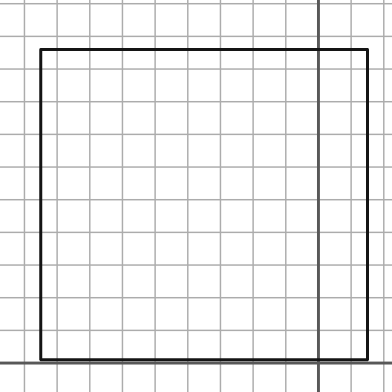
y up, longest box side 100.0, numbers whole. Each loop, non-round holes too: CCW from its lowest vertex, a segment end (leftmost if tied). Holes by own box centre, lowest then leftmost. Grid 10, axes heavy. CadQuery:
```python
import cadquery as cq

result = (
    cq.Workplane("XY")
    .moveTo(-85.0, 1.0)
    .lineTo(15.0, 1.0)
    .lineTo(15.0, 96.0)
    .lineTo(-85.0, 96.0)
    .close()
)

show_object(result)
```